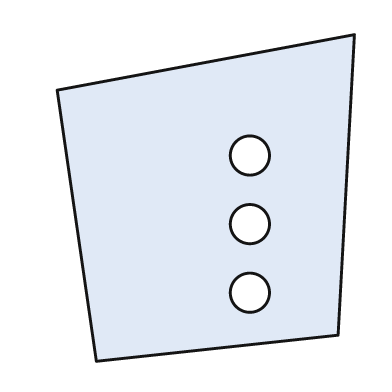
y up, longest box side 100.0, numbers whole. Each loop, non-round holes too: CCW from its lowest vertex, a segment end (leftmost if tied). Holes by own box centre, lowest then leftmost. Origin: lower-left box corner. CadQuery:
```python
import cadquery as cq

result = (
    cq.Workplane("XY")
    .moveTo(12.0, 0.0)
    .lineTo(86.0, 8.0)
    .lineTo(91.0, 100.0)
    .lineTo(0.0, 83.0)
    .close()
    .moveTo(59.0, 21.0)
    .circle(6.0)
    .moveTo(59.0, 42.0)
    .circle(6.0)
    .moveTo(59.0, 63.0)
    .circle(6.0)
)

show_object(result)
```